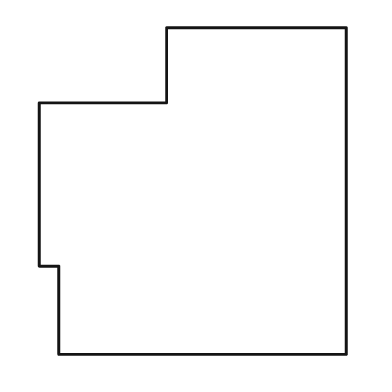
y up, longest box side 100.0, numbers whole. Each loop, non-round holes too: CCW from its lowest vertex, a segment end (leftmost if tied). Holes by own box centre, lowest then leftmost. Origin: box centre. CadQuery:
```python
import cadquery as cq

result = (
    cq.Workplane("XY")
    .moveTo(-41.0, -50.0)
    .lineTo(47.0, -50.0)
    .lineTo(47.0, 50.0)
    .lineTo(-8.0, 50.0)
    .lineTo(-8.0, 27.0)
    .lineTo(-47.0, 27.0)
    .lineTo(-47.0, -23.0)
    .lineTo(-41.0, -23.0)
    .close()
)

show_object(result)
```